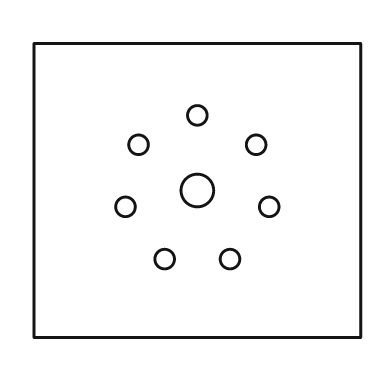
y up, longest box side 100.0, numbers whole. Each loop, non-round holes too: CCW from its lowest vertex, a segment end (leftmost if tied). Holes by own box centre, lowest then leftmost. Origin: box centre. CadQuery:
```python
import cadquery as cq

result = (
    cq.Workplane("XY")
    .moveTo(-50.0, -45.0)
    .lineTo(50.0, -45.0)
    .lineTo(50.0, 45.0)
    .lineTo(-50.0, 45.0)
    .close()
    .moveTo(-10.0, -21.0)
    .circle(3.0)
    .moveTo(10.0, -21.0)
    .circle(3.0)
    .moveTo(-22.0, -5.0)
    .circle(3.0)
    .moveTo(22.0, -5.0)
    .circle(3.0)
    .moveTo(0.0, 0.0)
    .circle(5.0)
    .moveTo(-18.0, 14.0)
    .circle(3.0)
    .moveTo(18.0, 14.0)
    .circle(3.0)
    .moveTo(0.0, 23.0)
    .circle(3.0)
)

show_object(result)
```